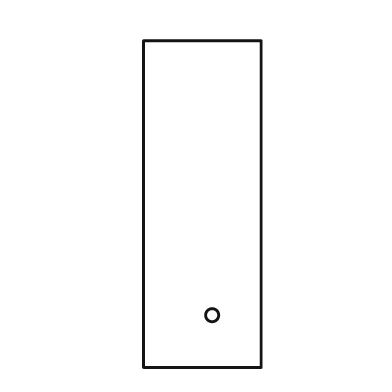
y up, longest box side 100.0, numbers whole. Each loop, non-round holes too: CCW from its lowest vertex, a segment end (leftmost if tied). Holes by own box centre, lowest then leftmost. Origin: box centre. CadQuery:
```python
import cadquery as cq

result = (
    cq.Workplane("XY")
    .moveTo(-18.0, -50.0)
    .lineTo(18.0, -50.0)
    .lineTo(18.0, 50.0)
    .lineTo(-18.0, 50.0)
    .close()
    .moveTo(3.0, -34.0)
    .circle(2.0)
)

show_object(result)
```